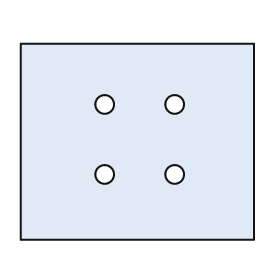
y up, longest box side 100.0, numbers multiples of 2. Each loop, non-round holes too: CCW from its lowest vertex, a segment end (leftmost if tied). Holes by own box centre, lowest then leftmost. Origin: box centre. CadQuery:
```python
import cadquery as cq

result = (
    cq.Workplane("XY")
    .moveTo(-50.0, -42.0)
    .lineTo(50.0, -42.0)
    .lineTo(50.0, 42.0)
    .lineTo(-50.0, 42.0)
    .close()
    .moveTo(-14.0, -14.0)
    .circle(4.0)
    .moveTo(16.0, -14.0)
    .circle(4.0)
    .moveTo(-14.0, 16.0)
    .circle(4.0)
    .moveTo(16.0, 16.0)
    .circle(4.0)
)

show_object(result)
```